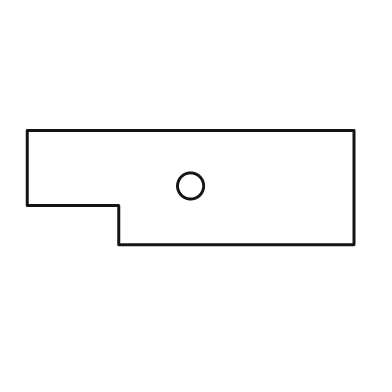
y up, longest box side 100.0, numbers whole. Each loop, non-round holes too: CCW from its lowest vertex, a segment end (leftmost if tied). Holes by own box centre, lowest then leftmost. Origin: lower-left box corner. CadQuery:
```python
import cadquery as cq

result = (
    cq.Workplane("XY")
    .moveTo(28.0, 0.0)
    .lineTo(100.0, 0.0)
    .lineTo(100.0, 35.0)
    .lineTo(0.0, 35.0)
    .lineTo(0.0, 12.0)
    .lineTo(28.0, 12.0)
    .close()
    .moveTo(50.0, 18.0)
    .circle(4.0)
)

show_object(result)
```